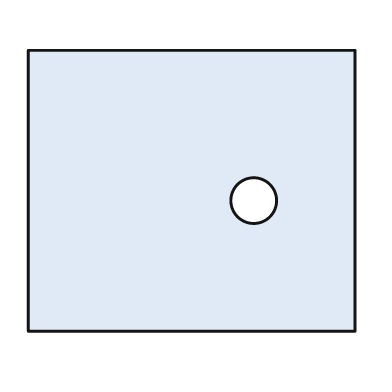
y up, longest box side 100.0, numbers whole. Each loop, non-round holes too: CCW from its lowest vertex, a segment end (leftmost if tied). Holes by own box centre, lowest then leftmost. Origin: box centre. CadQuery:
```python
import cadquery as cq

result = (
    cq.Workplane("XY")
    .moveTo(-50.0, -43.0)
    .lineTo(50.0, -43.0)
    .lineTo(50.0, 43.0)
    .lineTo(-50.0, 43.0)
    .close()
    .moveTo(19.0, -3.0)
    .circle(7.0)
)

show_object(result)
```